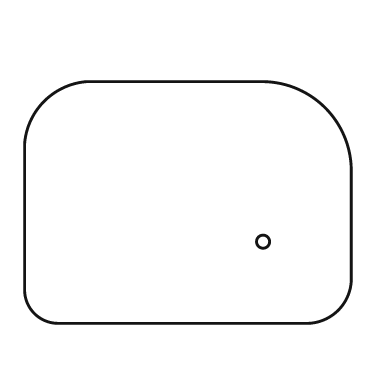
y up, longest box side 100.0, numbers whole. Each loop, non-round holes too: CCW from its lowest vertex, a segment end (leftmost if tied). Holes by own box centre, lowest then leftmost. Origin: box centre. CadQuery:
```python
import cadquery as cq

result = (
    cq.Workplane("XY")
    .moveTo(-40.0, -37.0)
    .lineTo(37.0, -37.0)
    .threePointArc((46.0, -33.0), (50.0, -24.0))
    .lineTo(50.0, 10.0)
    .threePointArc((42.0, 29.0), (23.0, 37.0))
    .lineTo(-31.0, 37.0)
    .threePointArc((-44.0, 31.0), (-50.0, 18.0))
    .lineTo(-50.0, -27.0)
    .threePointArc((-47.0, -34.0), (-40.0, -37.0))
    .close()
    .moveTo(23.0, -12.0)
    .circle(2.0)
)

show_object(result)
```